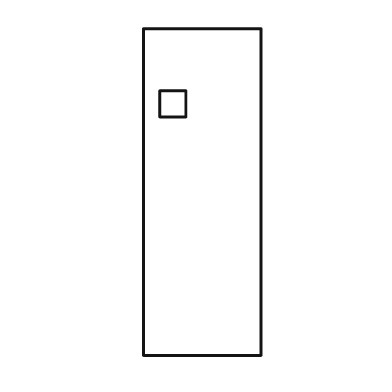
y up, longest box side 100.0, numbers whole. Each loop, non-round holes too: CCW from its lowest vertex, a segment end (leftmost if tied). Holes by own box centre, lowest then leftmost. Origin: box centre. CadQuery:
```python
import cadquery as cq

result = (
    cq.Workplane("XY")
    .moveTo(-18.0, -50.0)
    .lineTo(18.0, -50.0)
    .lineTo(18.0, 50.0)
    .lineTo(-18.0, 50.0)
    .close()
    .moveTo(-13.0, 23.0)
    .lineTo(-5.0, 23.0)
    .lineTo(-5.0, 31.0)
    .lineTo(-13.0, 31.0)
    .close()
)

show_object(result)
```